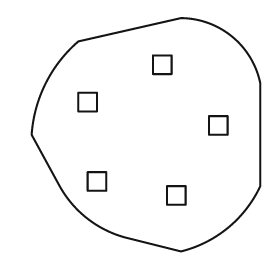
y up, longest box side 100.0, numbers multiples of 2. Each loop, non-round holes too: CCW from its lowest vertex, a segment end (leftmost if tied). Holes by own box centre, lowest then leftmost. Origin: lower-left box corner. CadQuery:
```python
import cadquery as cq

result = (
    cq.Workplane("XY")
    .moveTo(64.0, 0.0)
    .threePointArc((84.0, 10.0), (98.0, 28.0))
    .lineTo(98.0, 72.0)
    .threePointArc((86.0, 92.0), (64.0, 100.0))
    .lineTo(20.0, 90.0)
    .threePointArc((6.0, 72.0), (0.0, 50.0))
    .lineTo(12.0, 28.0)
    .threePointArc((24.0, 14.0), (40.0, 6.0))
    .close()
    .moveTo(58.0, 20.0)
    .lineTo(66.0, 20.0)
    .lineTo(66.0, 28.0)
    .lineTo(58.0, 28.0)
    .close()
    .moveTo(24.0, 26.0)
    .lineTo(32.0, 26.0)
    .lineTo(32.0, 34.0)
    .lineTo(24.0, 34.0)
    .close()
    .moveTo(76.0, 50.0)
    .lineTo(84.0, 50.0)
    .lineTo(84.0, 58.0)
    .lineTo(76.0, 58.0)
    .close()
    .moveTo(20.0, 60.0)
    .lineTo(28.0, 60.0)
    .lineTo(28.0, 68.0)
    .lineTo(20.0, 68.0)
    .close()
    .moveTo(52.0, 76.0)
    .lineTo(60.0, 76.0)
    .lineTo(60.0, 84.0)
    .lineTo(52.0, 84.0)
    .close()
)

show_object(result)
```